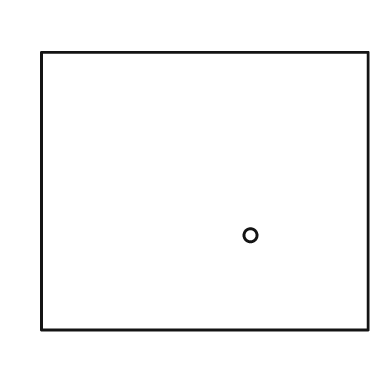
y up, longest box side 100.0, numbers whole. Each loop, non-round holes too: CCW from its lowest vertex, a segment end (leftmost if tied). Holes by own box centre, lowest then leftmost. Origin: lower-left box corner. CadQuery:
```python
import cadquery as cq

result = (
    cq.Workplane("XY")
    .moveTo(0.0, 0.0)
    .lineTo(100.0, 0.0)
    .lineTo(100.0, 85.0)
    .lineTo(0.0, 85.0)
    .close()
    .moveTo(64.0, 29.0)
    .circle(2.0)
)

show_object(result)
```